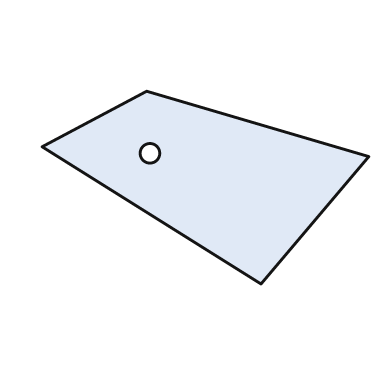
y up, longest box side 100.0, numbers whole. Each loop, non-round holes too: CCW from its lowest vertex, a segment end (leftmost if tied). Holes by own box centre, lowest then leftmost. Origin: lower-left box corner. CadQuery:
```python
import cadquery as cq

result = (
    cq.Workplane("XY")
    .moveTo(67.0, 0.0)
    .lineTo(100.0, 39.0)
    .lineTo(32.0, 59.0)
    .lineTo(0.0, 42.0)
    .close()
    .moveTo(33.0, 40.0)
    .circle(3.0)
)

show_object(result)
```